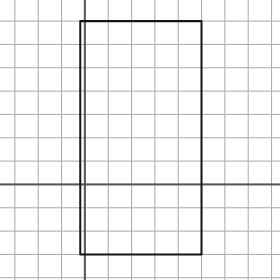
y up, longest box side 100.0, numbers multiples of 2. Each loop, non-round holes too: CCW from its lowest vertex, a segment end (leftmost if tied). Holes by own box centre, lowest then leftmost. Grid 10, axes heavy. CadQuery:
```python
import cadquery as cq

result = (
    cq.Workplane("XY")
    .moveTo(-2.0, -30.0)
    .lineTo(50.0, -30.0)
    .lineTo(50.0, 70.0)
    .lineTo(-2.0, 70.0)
    .close()
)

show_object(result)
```